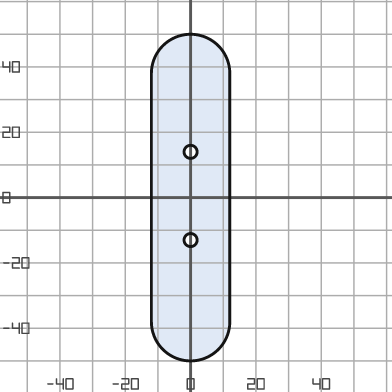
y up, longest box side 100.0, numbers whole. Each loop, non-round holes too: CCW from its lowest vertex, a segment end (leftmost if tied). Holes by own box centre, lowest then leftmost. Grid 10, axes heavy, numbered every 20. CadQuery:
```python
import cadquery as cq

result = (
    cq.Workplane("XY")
    .moveTo(-12.0, -38.0)
    .threePointArc((0.0, -50.0), (12.0, -38.0))
    .lineTo(12.0, 38.0)
    .threePointArc((0.0, 50.0), (-12.0, 38.0))
    .close()
    .moveTo(0.0, -13.0)
    .circle(2.0)
    .moveTo(0.0, 14.0)
    .circle(2.0)
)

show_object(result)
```